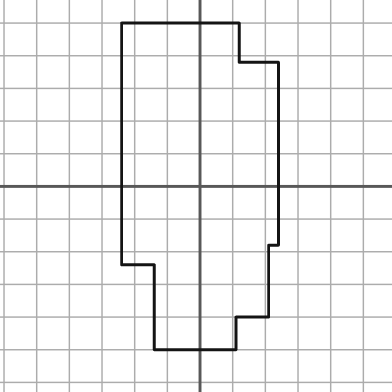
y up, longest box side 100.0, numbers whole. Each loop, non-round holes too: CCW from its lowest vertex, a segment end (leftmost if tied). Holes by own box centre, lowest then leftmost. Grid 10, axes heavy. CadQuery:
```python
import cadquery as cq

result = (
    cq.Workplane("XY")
    .moveTo(-14.0, -50.0)
    .lineTo(11.0, -50.0)
    .lineTo(11.0, -40.0)
    .lineTo(21.0, -40.0)
    .lineTo(21.0, -18.0)
    .lineTo(24.0, -18.0)
    .lineTo(24.0, 38.0)
    .lineTo(12.0, 38.0)
    .lineTo(12.0, 50.0)
    .lineTo(-24.0, 50.0)
    .lineTo(-24.0, -24.0)
    .lineTo(-14.0, -24.0)
    .close()
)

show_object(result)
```